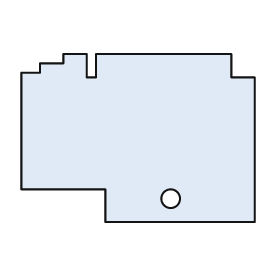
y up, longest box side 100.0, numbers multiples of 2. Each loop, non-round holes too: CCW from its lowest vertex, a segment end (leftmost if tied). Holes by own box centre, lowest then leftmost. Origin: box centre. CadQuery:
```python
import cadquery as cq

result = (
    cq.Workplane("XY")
    .moveTo(-14.0, -36.0)
    .lineTo(50.0, -36.0)
    .lineTo(50.0, 26.0)
    .lineTo(40.0, 26.0)
    .lineTo(40.0, 36.0)
    .lineTo(-18.0, 36.0)
    .lineTo(-18.0, 26.0)
    .lineTo(-22.0, 26.0)
    .lineTo(-22.0, 36.0)
    .lineTo(-32.0, 36.0)
    .lineTo(-32.0, 32.0)
    .lineTo(-42.0, 32.0)
    .lineTo(-42.0, 28.0)
    .lineTo(-50.0, 28.0)
    .lineTo(-50.0, -22.0)
    .lineTo(-14.0, -22.0)
    .close()
    .moveTo(14.0, -26.0)
    .circle(4.0)
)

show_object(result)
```